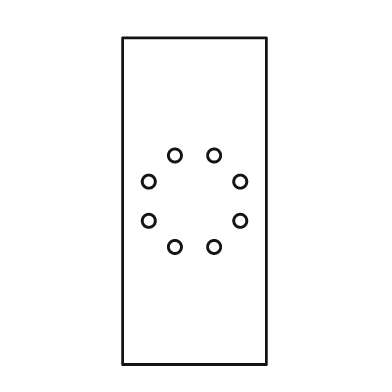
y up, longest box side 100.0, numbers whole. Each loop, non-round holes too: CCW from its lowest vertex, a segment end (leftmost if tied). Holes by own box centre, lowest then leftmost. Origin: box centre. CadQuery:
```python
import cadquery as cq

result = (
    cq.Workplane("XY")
    .moveTo(-22.0, -50.0)
    .lineTo(22.0, -50.0)
    .lineTo(22.0, 50.0)
    .lineTo(-22.0, 50.0)
    .close()
    .moveTo(-6.0, -14.0)
    .circle(2.0)
    .moveTo(6.0, -14.0)
    .circle(2.0)
    .moveTo(-14.0, -6.0)
    .circle(2.0)
    .moveTo(14.0, -6.0)
    .circle(2.0)
    .moveTo(-14.0, 6.0)
    .circle(2.0)
    .moveTo(14.0, 6.0)
    .circle(2.0)
    .moveTo(-6.0, 14.0)
    .circle(2.0)
    .moveTo(6.0, 14.0)
    .circle(2.0)
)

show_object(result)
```